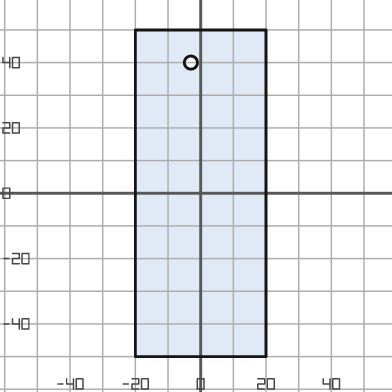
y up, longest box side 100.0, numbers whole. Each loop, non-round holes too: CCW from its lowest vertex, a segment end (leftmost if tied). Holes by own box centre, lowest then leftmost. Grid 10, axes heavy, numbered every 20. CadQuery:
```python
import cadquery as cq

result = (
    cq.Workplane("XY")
    .moveTo(-20.0, -50.0)
    .lineTo(20.0, -50.0)
    .lineTo(20.0, 50.0)
    .lineTo(-20.0, 50.0)
    .close()
    .moveTo(-3.0, 40.0)
    .circle(2.0)
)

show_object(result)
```